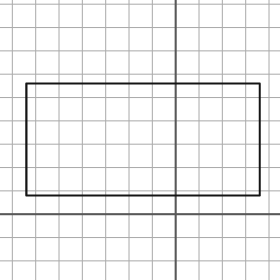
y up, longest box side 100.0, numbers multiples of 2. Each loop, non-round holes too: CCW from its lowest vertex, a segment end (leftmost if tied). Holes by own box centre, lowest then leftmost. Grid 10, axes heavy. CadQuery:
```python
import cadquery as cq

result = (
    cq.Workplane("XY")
    .moveTo(-64.0, 8.0)
    .lineTo(36.0, 8.0)
    .lineTo(36.0, 56.0)
    .lineTo(-64.0, 56.0)
    .close()
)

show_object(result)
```